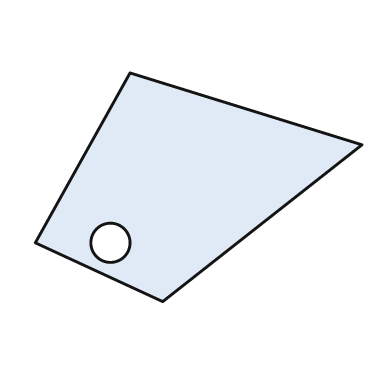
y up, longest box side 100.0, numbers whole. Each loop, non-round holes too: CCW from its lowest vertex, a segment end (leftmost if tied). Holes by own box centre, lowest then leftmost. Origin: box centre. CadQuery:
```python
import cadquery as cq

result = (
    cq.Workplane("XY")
    .moveTo(-11.0, -35.0)
    .lineTo(50.0, 13.0)
    .lineTo(-21.0, 35.0)
    .lineTo(-50.0, -17.0)
    .close()
    .moveTo(-27.0, -17.0)
    .circle(6.0)
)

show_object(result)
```